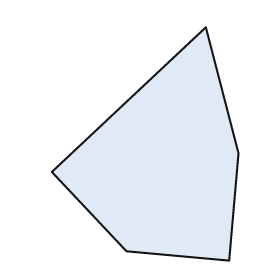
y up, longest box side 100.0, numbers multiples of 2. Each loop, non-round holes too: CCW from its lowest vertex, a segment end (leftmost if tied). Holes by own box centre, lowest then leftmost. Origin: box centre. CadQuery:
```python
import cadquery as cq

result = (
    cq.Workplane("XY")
    .moveTo(36.0, -50.0)
    .lineTo(40.0, -4.0)
    .lineTo(26.0, 50.0)
    .lineTo(-40.0, -12.0)
    .lineTo(-8.0, -46.0)
    .close()
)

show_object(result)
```